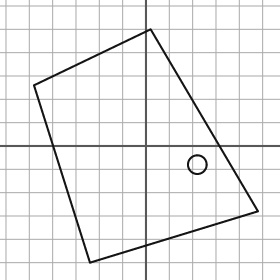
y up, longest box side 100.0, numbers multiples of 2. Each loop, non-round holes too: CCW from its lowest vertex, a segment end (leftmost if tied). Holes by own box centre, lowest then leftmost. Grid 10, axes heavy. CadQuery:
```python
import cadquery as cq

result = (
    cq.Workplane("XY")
    .moveTo(-24.0, -50.0)
    .lineTo(48.0, -28.0)
    .lineTo(2.0, 50.0)
    .lineTo(-48.0, 26.0)
    .close()
    .moveTo(22.0, -8.0)
    .circle(4.0)
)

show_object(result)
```